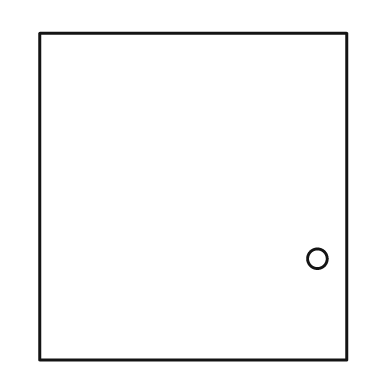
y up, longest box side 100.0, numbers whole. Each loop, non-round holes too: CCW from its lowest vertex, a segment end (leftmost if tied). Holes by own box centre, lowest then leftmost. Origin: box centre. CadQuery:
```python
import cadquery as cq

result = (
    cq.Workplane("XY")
    .moveTo(-47.0, -50.0)
    .lineTo(47.0, -50.0)
    .lineTo(47.0, 50.0)
    .lineTo(-47.0, 50.0)
    .close()
    .moveTo(38.0, -19.0)
    .circle(3.0)
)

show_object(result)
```